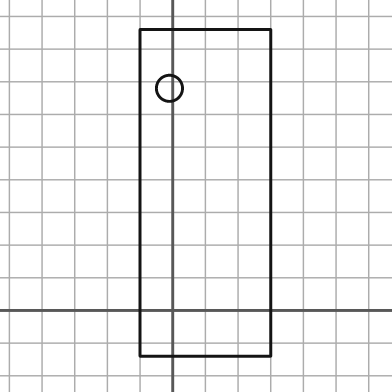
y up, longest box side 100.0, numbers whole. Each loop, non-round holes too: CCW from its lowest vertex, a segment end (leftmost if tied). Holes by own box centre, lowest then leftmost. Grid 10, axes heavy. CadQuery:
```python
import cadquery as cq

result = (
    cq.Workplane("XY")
    .moveTo(-10.0, -14.0)
    .lineTo(30.0, -14.0)
    .lineTo(30.0, 86.0)
    .lineTo(-10.0, 86.0)
    .close()
    .moveTo(-1.0, 68.0)
    .circle(4.0)
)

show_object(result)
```